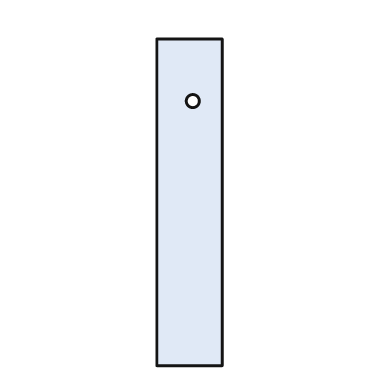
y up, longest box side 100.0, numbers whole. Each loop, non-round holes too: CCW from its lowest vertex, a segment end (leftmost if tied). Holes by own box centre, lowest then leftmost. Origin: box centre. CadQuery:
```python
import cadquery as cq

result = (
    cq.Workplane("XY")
    .moveTo(-10.0, -50.0)
    .lineTo(10.0, -50.0)
    .lineTo(10.0, 50.0)
    .lineTo(-10.0, 50.0)
    .close()
    .moveTo(1.0, 31.0)
    .circle(2.0)
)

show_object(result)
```